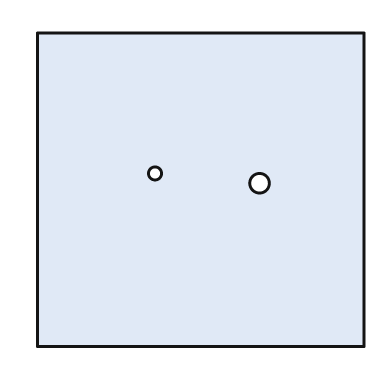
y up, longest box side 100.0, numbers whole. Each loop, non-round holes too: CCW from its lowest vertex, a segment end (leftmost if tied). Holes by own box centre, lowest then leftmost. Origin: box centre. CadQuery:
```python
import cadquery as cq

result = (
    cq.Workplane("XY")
    .moveTo(-50.0, -48.0)
    .lineTo(50.0, -48.0)
    .lineTo(50.0, 48.0)
    .lineTo(-50.0, 48.0)
    .close()
    .moveTo(18.0, 2.0)
    .circle(3.0)
    .moveTo(-14.0, 5.0)
    .circle(2.0)
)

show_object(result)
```